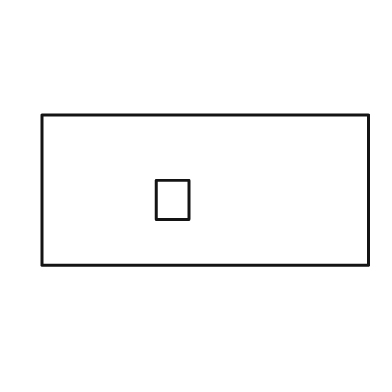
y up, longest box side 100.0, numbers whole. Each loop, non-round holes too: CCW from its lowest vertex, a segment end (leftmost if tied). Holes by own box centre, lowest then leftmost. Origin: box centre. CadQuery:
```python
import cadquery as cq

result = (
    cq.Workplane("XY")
    .moveTo(-50.0, -23.0)
    .lineTo(50.0, -23.0)
    .lineTo(50.0, 23.0)
    .lineTo(-50.0, 23.0)
    .close()
    .moveTo(-15.0, -9.0)
    .lineTo(-5.0, -9.0)
    .lineTo(-5.0, 3.0)
    .lineTo(-15.0, 3.0)
    .close()
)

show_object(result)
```